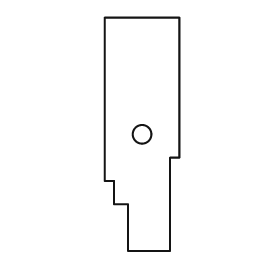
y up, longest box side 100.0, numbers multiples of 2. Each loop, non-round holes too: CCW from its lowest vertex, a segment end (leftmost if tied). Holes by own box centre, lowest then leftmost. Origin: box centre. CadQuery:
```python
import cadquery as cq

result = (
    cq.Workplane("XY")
    .moveTo(-6.0, -50.0)
    .lineTo(12.0, -50.0)
    .lineTo(12.0, -10.0)
    .lineTo(16.0, -10.0)
    .lineTo(16.0, 50.0)
    .lineTo(-16.0, 50.0)
    .lineTo(-16.0, -20.0)
    .lineTo(-12.0, -20.0)
    .lineTo(-12.0, -30.0)
    .lineTo(-6.0, -30.0)
    .close()
    .moveTo(0.0, 0.0)
    .circle(4.0)
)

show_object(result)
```